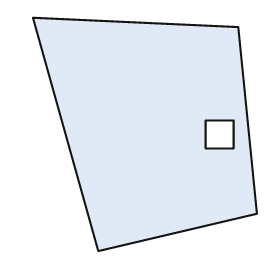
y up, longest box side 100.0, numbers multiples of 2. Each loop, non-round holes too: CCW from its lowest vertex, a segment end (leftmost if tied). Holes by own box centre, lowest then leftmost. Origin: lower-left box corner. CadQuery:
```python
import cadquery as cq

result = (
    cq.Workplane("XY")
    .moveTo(28.0, 0.0)
    .lineTo(96.0, 16.0)
    .lineTo(88.0, 96.0)
    .lineTo(0.0, 100.0)
    .close()
    .moveTo(74.0, 44.0)
    .lineTo(86.0, 44.0)
    .lineTo(86.0, 56.0)
    .lineTo(74.0, 56.0)
    .close()
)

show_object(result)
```